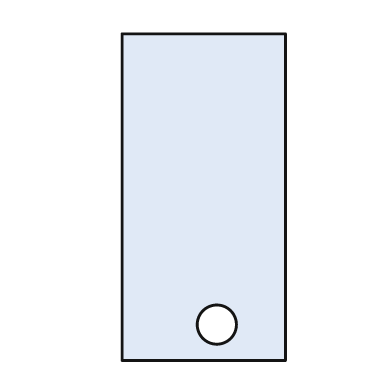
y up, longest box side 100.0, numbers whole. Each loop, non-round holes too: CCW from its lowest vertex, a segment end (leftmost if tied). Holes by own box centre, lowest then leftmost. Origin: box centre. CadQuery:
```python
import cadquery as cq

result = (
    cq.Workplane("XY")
    .moveTo(-25.0, -50.0)
    .lineTo(25.0, -50.0)
    .lineTo(25.0, 50.0)
    .lineTo(-25.0, 50.0)
    .close()
    .moveTo(4.0, -39.0)
    .circle(6.0)
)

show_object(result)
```